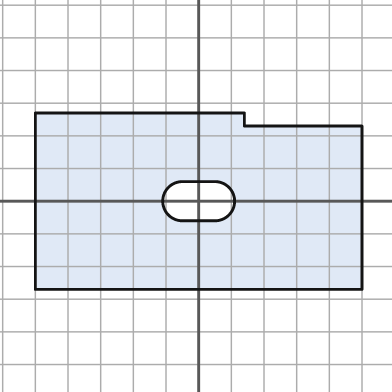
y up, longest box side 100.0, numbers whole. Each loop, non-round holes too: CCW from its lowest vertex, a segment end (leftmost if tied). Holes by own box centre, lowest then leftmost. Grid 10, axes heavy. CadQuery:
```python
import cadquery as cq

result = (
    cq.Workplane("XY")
    .moveTo(-50.0, -27.0)
    .lineTo(50.0, -27.0)
    .lineTo(50.0, 23.0)
    .lineTo(14.0, 23.0)
    .lineTo(14.0, 27.0)
    .lineTo(-50.0, 27.0)
    .close()
    .moveTo(-5.0, -6.0)
    .lineTo(5.0, -6.0)
    .threePointArc((11.0, 0.0), (5.0, 6.0))
    .lineTo(-5.0, 6.0)
    .threePointArc((-11.0, 0.0), (-5.0, -6.0))
    .close()
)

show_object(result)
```